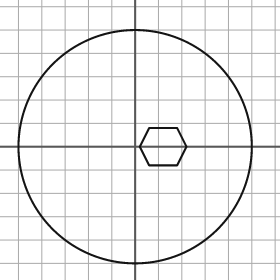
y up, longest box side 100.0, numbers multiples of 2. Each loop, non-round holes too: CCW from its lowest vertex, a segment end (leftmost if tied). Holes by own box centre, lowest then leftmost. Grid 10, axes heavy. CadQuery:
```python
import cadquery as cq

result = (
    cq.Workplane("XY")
    .moveTo(0.0, 0.0)
    .circle(50.0)
    .moveTo(6.0, -8.0)
    .lineTo(18.0, -8.0)
    .lineTo(22.0, 0.0)
    .lineTo(18.0, 8.0)
    .lineTo(6.0, 8.0)
    .lineTo(2.0, 0.0)
    .close()
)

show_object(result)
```